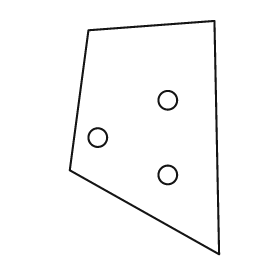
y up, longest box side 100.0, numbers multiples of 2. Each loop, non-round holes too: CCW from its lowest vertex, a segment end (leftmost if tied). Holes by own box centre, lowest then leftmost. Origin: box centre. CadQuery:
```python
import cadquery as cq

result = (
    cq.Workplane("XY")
    .moveTo(32.0, -50.0)
    .lineTo(30.0, 50.0)
    .lineTo(-24.0, 46.0)
    .lineTo(-32.0, -14.0)
    .close()
    .moveTo(10.0, -16.0)
    .circle(4.0)
    .moveTo(-20.0, 0.0)
    .circle(4.0)
    .moveTo(10.0, 16.0)
    .circle(4.0)
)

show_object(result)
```